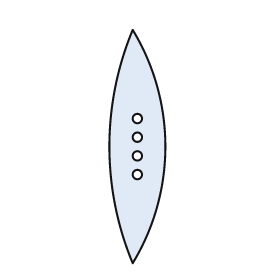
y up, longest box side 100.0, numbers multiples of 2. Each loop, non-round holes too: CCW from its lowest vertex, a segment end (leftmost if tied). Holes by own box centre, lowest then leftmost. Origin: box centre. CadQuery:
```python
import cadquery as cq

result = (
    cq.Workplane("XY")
    .moveTo(-2.0, -50.0)
    .threePointArc((12.0, 0.0), (-2.0, 50.0))
    .threePointArc((-12.0, 0.0), (-2.0, -50.0))
    .close()
    .moveTo(0.0, -12.0)
    .circle(2.0)
    .moveTo(0.0, -4.0)
    .circle(2.0)
    .moveTo(0.0, 4.0)
    .circle(2.0)
    .moveTo(0.0, 12.0)
    .circle(2.0)
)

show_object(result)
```